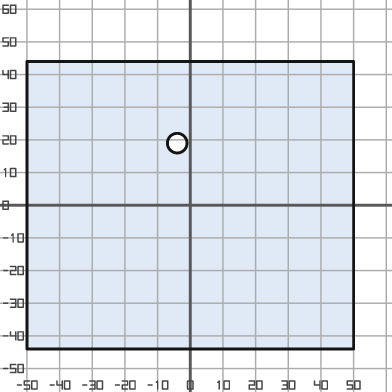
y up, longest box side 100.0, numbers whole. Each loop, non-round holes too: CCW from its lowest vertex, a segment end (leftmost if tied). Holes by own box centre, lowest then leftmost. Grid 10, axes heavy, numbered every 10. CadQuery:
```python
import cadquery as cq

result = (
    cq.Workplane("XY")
    .moveTo(-50.0, -44.0)
    .lineTo(50.0, -44.0)
    .lineTo(50.0, 44.0)
    .lineTo(-50.0, 44.0)
    .close()
    .moveTo(-4.0, 19.0)
    .circle(3.0)
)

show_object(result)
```